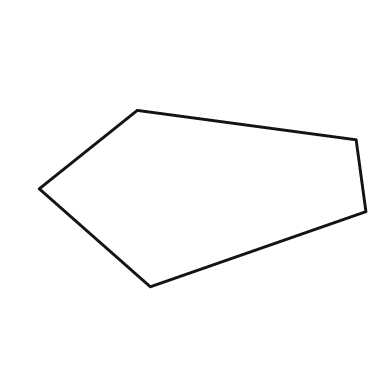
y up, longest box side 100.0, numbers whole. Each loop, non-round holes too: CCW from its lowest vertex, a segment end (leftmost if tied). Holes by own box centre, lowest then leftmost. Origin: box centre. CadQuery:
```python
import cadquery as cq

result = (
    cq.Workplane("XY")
    .moveTo(-16.0, -27.0)
    .lineTo(50.0, -4.0)
    .lineTo(47.0, 18.0)
    .lineTo(-20.0, 27.0)
    .lineTo(-50.0, 3.0)
    .close()
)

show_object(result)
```